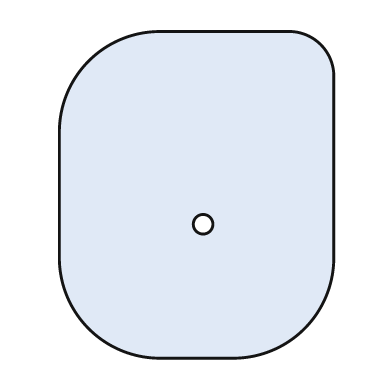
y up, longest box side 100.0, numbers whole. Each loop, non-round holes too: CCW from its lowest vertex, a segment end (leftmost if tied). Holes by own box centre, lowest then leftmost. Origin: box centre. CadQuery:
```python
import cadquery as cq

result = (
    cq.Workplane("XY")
    .moveTo(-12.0, -50.0)
    .lineTo(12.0, -50.0)
    .threePointArc((33.0, -41.0), (42.0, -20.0))
    .lineTo(42.0, 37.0)
    .threePointArc((38.0, 46.0), (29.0, 50.0))
    .lineTo(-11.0, 50.0)
    .threePointArc((-33.0, 41.0), (-42.0, 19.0))
    .lineTo(-42.0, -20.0)
    .threePointArc((-33.0, -41.0), (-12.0, -50.0))
    .close()
    .moveTo(2.0, -9.0)
    .circle(3.0)
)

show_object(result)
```